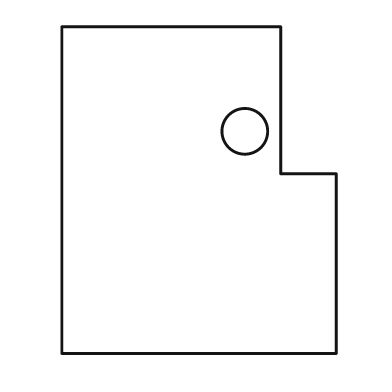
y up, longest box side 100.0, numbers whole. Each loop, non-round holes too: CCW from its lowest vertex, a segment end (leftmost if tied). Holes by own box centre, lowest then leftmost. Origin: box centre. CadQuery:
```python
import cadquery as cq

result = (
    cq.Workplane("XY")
    .moveTo(-42.0, -50.0)
    .lineTo(42.0, -50.0)
    .lineTo(42.0, 5.0)
    .lineTo(25.0, 5.0)
    .lineTo(25.0, 50.0)
    .lineTo(-42.0, 50.0)
    .close()
    .moveTo(14.0, 18.0)
    .circle(7.0)
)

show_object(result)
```